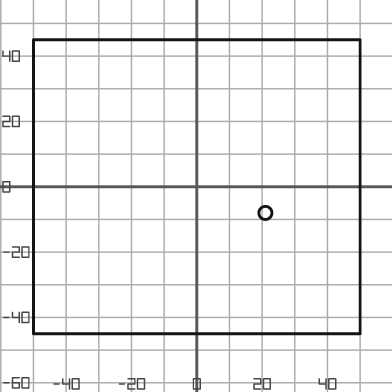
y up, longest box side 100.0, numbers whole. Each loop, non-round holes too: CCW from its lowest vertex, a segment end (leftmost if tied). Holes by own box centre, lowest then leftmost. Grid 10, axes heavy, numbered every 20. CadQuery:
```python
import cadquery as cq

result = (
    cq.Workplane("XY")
    .moveTo(-50.0, -45.0)
    .lineTo(50.0, -45.0)
    .lineTo(50.0, 45.0)
    .lineTo(-50.0, 45.0)
    .close()
    .moveTo(21.0, -8.0)
    .circle(2.0)
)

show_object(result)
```